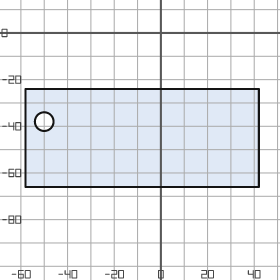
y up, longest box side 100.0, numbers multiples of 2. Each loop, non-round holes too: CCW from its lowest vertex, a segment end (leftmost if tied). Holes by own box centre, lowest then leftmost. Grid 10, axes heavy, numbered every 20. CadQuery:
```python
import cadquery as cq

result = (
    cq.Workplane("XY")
    .moveTo(-58.0, -66.0)
    .lineTo(42.0, -66.0)
    .lineTo(42.0, -24.0)
    .lineTo(-58.0, -24.0)
    .close()
    .moveTo(-50.0, -38.0)
    .circle(4.0)
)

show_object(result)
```